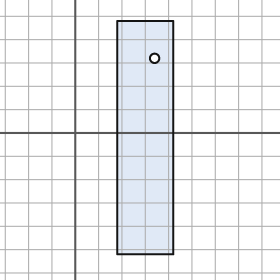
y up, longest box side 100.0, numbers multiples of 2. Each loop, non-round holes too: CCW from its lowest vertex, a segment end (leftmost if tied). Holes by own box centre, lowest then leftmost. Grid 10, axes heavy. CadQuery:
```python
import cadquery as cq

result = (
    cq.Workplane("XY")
    .moveTo(18.0, -52.0)
    .lineTo(42.0, -52.0)
    .lineTo(42.0, 48.0)
    .lineTo(18.0, 48.0)
    .close()
    .moveTo(34.0, 32.0)
    .circle(2.0)
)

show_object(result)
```